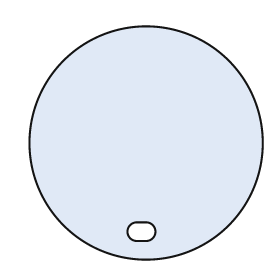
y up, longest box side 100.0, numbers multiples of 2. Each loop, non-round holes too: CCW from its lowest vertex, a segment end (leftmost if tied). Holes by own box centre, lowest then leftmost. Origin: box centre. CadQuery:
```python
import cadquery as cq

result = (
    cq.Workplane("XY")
    .moveTo(0.0, 0.0)
    .circle(50.0)
    .moveTo(-4.0, -42.0)
    .lineTo(0.0, -42.0)
    .threePointArc((4.0, -38.0), (0.0, -34.0))
    .lineTo(-4.0, -34.0)
    .threePointArc((-8.0, -38.0), (-4.0, -42.0))
    .close()
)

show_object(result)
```